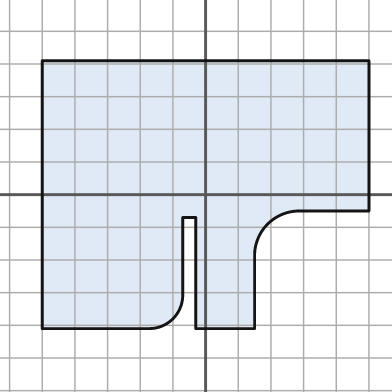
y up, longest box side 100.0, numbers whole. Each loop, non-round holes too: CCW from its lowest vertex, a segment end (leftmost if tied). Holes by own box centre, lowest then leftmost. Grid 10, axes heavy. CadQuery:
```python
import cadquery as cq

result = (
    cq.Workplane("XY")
    .moveTo(-50.0, -41.0)
    .lineTo(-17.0, -41.0)
    .threePointArc((-10.0, -38.0), (-7.0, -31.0))
    .lineTo(-7.0, -7.0)
    .lineTo(-3.0, -7.0)
    .lineTo(-3.0, -41.0)
    .lineTo(15.0, -41.0)
    .lineTo(15.0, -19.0)
    .threePointArc((19.0, -9.0), (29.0, -5.0))
    .lineTo(50.0, -5.0)
    .lineTo(50.0, 41.0)
    .lineTo(-50.0, 41.0)
    .close()
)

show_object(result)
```